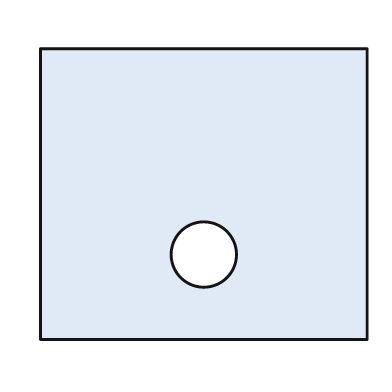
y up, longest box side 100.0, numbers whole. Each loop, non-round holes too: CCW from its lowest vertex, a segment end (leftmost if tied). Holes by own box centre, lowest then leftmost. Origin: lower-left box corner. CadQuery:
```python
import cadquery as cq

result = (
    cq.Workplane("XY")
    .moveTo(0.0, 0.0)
    .lineTo(100.0, 0.0)
    .lineTo(100.0, 89.0)
    .lineTo(0.0, 89.0)
    .close()
    .moveTo(50.0, 26.0)
    .circle(10.0)
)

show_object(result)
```